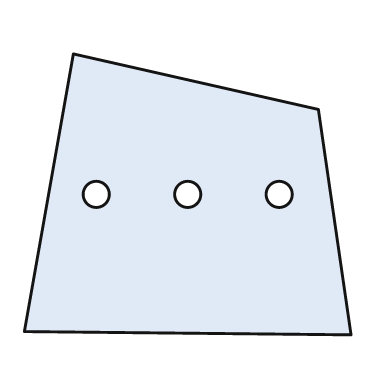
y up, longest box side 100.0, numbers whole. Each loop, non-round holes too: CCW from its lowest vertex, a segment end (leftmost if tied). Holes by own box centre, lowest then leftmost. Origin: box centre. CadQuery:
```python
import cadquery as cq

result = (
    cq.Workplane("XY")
    .moveTo(50.0, -43.0)
    .lineTo(40.0, 26.0)
    .lineTo(-35.0, 43.0)
    .lineTo(-50.0, -42.0)
    .close()
    .moveTo(-28.0, 0.0)
    .circle(4.0)
    .moveTo(0.0, 0.0)
    .circle(4.0)
    .moveTo(28.0, 0.0)
    .circle(4.0)
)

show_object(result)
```